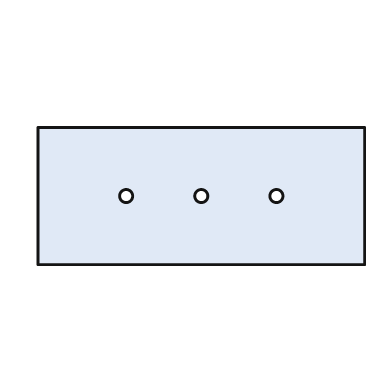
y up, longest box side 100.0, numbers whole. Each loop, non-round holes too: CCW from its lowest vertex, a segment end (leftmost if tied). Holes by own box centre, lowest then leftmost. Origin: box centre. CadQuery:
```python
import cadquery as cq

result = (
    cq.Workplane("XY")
    .moveTo(-50.0, -21.0)
    .lineTo(50.0, -21.0)
    .lineTo(50.0, 21.0)
    .lineTo(-50.0, 21.0)
    .close()
    .moveTo(-23.0, 0.0)
    .circle(2.0)
    .moveTo(0.0, 0.0)
    .circle(2.0)
    .moveTo(23.0, 0.0)
    .circle(2.0)
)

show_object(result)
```